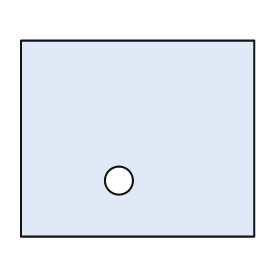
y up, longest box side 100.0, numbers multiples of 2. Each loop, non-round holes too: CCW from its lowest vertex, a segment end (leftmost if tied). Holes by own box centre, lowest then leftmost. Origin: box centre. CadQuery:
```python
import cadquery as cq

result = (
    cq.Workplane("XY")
    .moveTo(-50.0, -42.0)
    .lineTo(50.0, -42.0)
    .lineTo(50.0, 42.0)
    .lineTo(-50.0, 42.0)
    .close()
    .moveTo(-8.0, -18.0)
    .circle(6.0)
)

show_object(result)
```